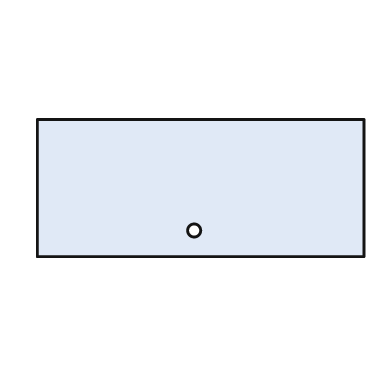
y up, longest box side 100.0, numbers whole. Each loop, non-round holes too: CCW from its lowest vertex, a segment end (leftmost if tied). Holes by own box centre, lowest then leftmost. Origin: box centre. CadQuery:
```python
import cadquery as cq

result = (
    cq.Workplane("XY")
    .moveTo(-50.0, -21.0)
    .lineTo(50.0, -21.0)
    .lineTo(50.0, 21.0)
    .lineTo(-50.0, 21.0)
    .close()
    .moveTo(-2.0, -13.0)
    .circle(2.0)
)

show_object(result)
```